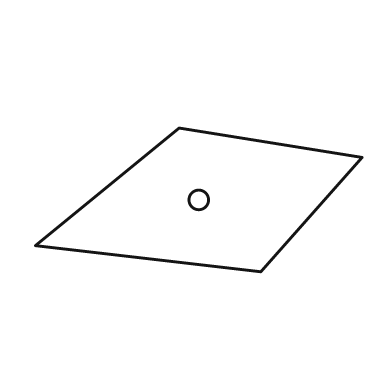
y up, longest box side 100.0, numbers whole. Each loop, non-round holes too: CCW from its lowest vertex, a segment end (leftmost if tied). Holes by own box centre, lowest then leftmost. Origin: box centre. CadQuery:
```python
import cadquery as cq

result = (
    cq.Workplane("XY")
    .moveTo(19.0, -22.0)
    .lineTo(50.0, 13.0)
    .lineTo(-6.0, 22.0)
    .lineTo(-50.0, -14.0)
    .close()
    .moveTo(0.0, 0.0)
    .circle(3.0)
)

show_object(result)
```